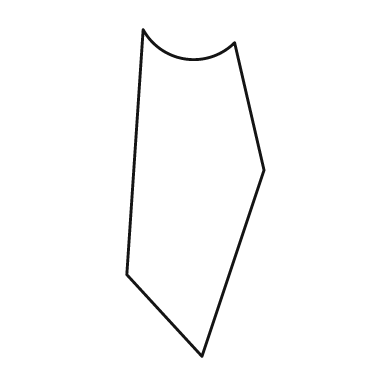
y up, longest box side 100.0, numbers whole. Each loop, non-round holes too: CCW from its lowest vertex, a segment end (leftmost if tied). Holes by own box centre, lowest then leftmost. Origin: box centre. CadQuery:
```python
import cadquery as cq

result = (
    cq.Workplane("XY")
    .moveTo(2.0, -50.0)
    .lineTo(21.0, 7.0)
    .lineTo(12.0, 46.0)
    .threePointArc((-3.0, 41.0), (-16.0, 50.0))
    .lineTo(-21.0, -25.0)
    .close()
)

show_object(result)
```